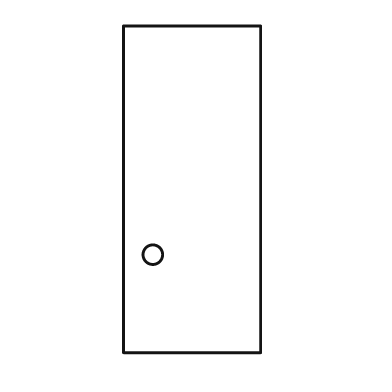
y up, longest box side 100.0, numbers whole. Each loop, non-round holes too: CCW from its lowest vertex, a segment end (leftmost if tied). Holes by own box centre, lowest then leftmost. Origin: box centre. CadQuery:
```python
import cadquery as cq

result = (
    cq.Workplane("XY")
    .moveTo(-21.0, -50.0)
    .lineTo(21.0, -50.0)
    .lineTo(21.0, 50.0)
    .lineTo(-21.0, 50.0)
    .close()
    .moveTo(-12.0, -20.0)
    .circle(3.0)
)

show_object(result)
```